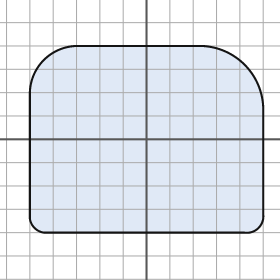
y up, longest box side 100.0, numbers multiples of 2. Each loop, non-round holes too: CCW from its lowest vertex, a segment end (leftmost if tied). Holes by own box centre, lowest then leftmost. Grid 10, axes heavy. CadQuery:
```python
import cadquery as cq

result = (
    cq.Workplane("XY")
    .moveTo(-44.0, -40.0)
    .lineTo(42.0, -40.0)
    .threePointArc((48.0, -38.0), (50.0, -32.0))
    .lineTo(50.0, 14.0)
    .threePointArc((42.0, 32.0), (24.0, 40.0))
    .lineTo(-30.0, 40.0)
    .threePointArc((-44.0, 34.0), (-50.0, 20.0))
    .lineTo(-50.0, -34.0)
    .threePointArc((-48.0, -38.0), (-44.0, -40.0))
    .close()
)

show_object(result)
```